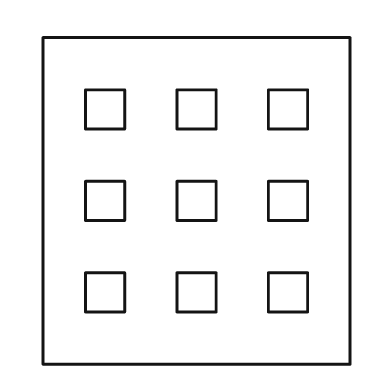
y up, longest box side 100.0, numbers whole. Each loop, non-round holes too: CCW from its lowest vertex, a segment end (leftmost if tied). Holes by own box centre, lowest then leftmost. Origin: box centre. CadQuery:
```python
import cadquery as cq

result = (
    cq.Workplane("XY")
    .moveTo(-47.0, -50.0)
    .lineTo(47.0, -50.0)
    .lineTo(47.0, 50.0)
    .lineTo(-47.0, 50.0)
    .close()
    .moveTo(-34.0, -34.0)
    .lineTo(-22.0, -34.0)
    .lineTo(-22.0, -22.0)
    .lineTo(-34.0, -22.0)
    .close()
    .moveTo(-6.0, -34.0)
    .lineTo(6.0, -34.0)
    .lineTo(6.0, -22.0)
    .lineTo(-6.0, -22.0)
    .close()
    .moveTo(22.0, -34.0)
    .lineTo(34.0, -34.0)
    .lineTo(34.0, -22.0)
    .lineTo(22.0, -22.0)
    .close()
    .moveTo(-34.0, -6.0)
    .lineTo(-22.0, -6.0)
    .lineTo(-22.0, 6.0)
    .lineTo(-34.0, 6.0)
    .close()
    .moveTo(-6.0, -6.0)
    .lineTo(6.0, -6.0)
    .lineTo(6.0, 6.0)
    .lineTo(-6.0, 6.0)
    .close()
    .moveTo(22.0, -6.0)
    .lineTo(34.0, -6.0)
    .lineTo(34.0, 6.0)
    .lineTo(22.0, 6.0)
    .close()
    .moveTo(-34.0, 22.0)
    .lineTo(-22.0, 22.0)
    .lineTo(-22.0, 34.0)
    .lineTo(-34.0, 34.0)
    .close()
    .moveTo(-6.0, 22.0)
    .lineTo(6.0, 22.0)
    .lineTo(6.0, 34.0)
    .lineTo(-6.0, 34.0)
    .close()
    .moveTo(22.0, 22.0)
    .lineTo(34.0, 22.0)
    .lineTo(34.0, 34.0)
    .lineTo(22.0, 34.0)
    .close()
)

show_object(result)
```